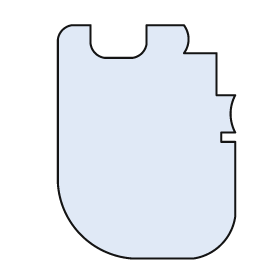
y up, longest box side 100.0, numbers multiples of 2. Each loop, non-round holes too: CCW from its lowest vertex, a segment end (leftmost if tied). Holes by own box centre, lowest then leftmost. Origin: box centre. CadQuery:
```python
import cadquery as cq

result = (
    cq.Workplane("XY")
    .moveTo(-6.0, -50.0)
    .lineTo(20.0, -50.0)
    .threePointArc((32.0, -44.0), (38.0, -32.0))
    .lineTo(38.0, 0.0)
    .lineTo(32.0, 0.0)
    .lineTo(32.0, 4.0)
    .lineTo(38.0, 4.0)
    .threePointArc((36.0, 12.0), (38.0, 20.0))
    .lineTo(30.0, 20.0)
    .lineTo(30.0, 38.0)
    .lineTo(16.0, 38.0)
    .threePointArc((18.0, 44.0), (16.0, 50.0))
    .lineTo(0.0, 50.0)
    .lineTo(0.0, 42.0)
    .threePointArc((-2.0, 38.0), (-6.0, 36.0))
    .lineTo(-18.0, 36.0)
    .threePointArc((-22.0, 38.0), (-24.0, 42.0))
    .lineTo(-24.0, 50.0)
    .lineTo(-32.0, 50.0)
    .threePointArc((-36.0, 48.0), (-38.0, 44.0))
    .lineTo(-38.0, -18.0)
    .threePointArc((-28.0, -40.0), (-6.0, -50.0))
    .close()
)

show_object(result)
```